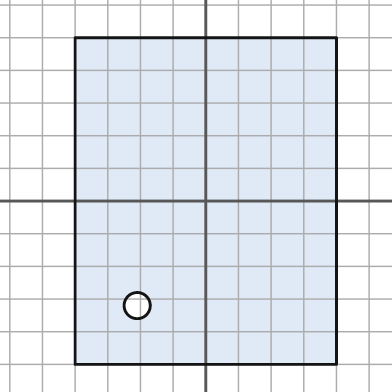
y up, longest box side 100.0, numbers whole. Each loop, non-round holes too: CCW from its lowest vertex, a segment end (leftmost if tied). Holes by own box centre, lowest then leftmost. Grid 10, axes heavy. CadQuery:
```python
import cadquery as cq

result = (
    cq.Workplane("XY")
    .moveTo(-40.0, -50.0)
    .lineTo(40.0, -50.0)
    .lineTo(40.0, 50.0)
    .lineTo(-40.0, 50.0)
    .close()
    .moveTo(-21.0, -32.0)
    .circle(4.0)
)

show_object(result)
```